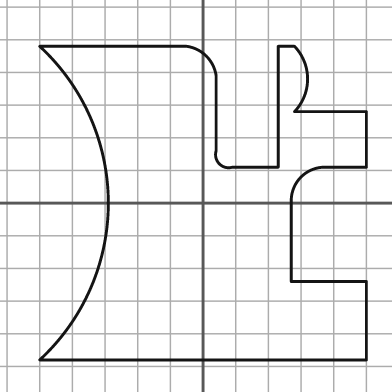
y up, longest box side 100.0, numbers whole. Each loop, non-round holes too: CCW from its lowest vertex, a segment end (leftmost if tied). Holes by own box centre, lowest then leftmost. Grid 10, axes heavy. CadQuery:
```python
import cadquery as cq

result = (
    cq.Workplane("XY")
    .moveTo(-50.0, -48.0)
    .lineTo(50.0, -48.0)
    .lineTo(50.0, -24.0)
    .lineTo(27.0, -24.0)
    .lineTo(27.0, 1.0)
    .threePointArc((30.0, 8.0), (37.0, 11.0))
    .lineTo(50.0, 11.0)
    .lineTo(50.0, 28.0)
    .lineTo(28.0, 28.0)
    .threePointArc((32.0, 38.0), (28.0, 48.0))
    .lineTo(23.0, 48.0)
    .lineTo(23.0, 11.0)
    .lineTo(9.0, 11.0)
    .threePointArc((5.0, 12.0), (4.0, 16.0))
    .lineTo(4.0, 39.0)
    .threePointArc((1.0, 45.0), (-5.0, 48.0))
    .lineTo(-50.0, 48.0)
    .threePointArc((-29.0, 0.0), (-50.0, -48.0))
    .close()
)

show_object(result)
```